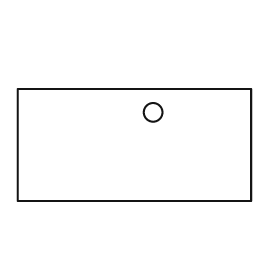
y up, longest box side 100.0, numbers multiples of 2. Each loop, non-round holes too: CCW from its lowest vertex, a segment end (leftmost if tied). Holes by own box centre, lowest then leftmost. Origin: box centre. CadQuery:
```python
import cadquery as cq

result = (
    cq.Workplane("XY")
    .moveTo(-50.0, -24.0)
    .lineTo(50.0, -24.0)
    .lineTo(50.0, 24.0)
    .lineTo(-50.0, 24.0)
    .close()
    .moveTo(8.0, 14.0)
    .circle(4.0)
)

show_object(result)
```